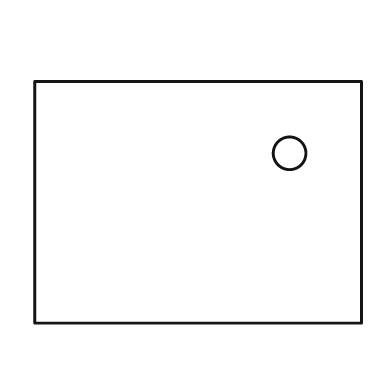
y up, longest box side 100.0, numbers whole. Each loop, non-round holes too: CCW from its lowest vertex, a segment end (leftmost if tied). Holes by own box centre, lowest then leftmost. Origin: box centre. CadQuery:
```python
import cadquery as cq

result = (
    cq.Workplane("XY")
    .moveTo(-50.0, -37.0)
    .lineTo(50.0, -37.0)
    .lineTo(50.0, 37.0)
    .lineTo(-50.0, 37.0)
    .close()
    .moveTo(28.0, 15.0)
    .circle(5.0)
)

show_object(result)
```